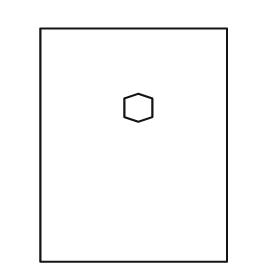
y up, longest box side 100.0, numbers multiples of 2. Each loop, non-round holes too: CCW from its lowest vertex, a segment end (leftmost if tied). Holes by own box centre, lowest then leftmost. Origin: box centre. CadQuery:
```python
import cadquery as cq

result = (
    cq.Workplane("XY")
    .moveTo(-40.0, -50.0)
    .lineTo(40.0, -50.0)
    .lineTo(40.0, 50.0)
    .lineTo(-40.0, 50.0)
    .close()
    .moveTo(2.0, 10.0)
    .lineTo(8.0, 12.0)
    .lineTo(8.0, 20.0)
    .lineTo(2.0, 22.0)
    .lineTo(-4.0, 20.0)
    .lineTo(-4.0, 12.0)
    .close()
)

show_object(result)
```